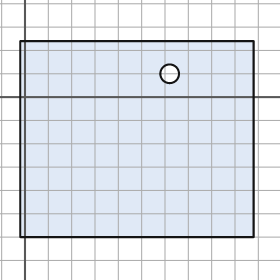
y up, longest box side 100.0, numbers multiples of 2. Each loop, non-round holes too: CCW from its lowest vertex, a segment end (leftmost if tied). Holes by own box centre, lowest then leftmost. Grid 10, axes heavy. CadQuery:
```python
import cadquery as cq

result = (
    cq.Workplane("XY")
    .moveTo(-2.0, -60.0)
    .lineTo(98.0, -60.0)
    .lineTo(98.0, 24.0)
    .lineTo(-2.0, 24.0)
    .close()
    .moveTo(62.0, 10.0)
    .circle(4.0)
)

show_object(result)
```